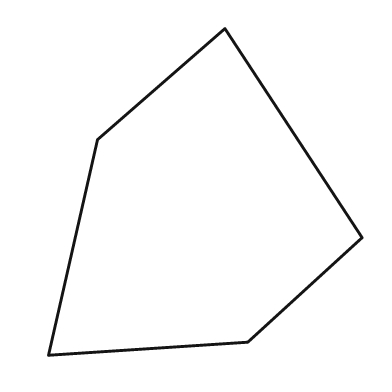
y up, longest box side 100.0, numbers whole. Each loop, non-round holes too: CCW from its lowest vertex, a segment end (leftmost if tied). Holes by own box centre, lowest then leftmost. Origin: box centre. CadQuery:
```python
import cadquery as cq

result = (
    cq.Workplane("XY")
    .moveTo(-48.0, -50.0)
    .lineTo(13.0, -46.0)
    .lineTo(48.0, -14.0)
    .lineTo(6.0, 50.0)
    .lineTo(-33.0, 16.0)
    .close()
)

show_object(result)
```